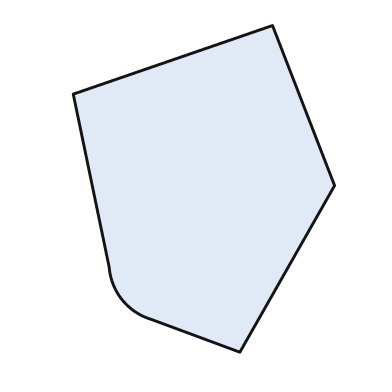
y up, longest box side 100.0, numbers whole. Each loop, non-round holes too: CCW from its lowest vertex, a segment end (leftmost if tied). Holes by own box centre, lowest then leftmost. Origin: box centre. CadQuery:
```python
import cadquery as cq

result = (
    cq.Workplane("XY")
    .moveTo(11.0, -50.0)
    .lineTo(40.0, 1.0)
    .lineTo(21.0, 50.0)
    .lineTo(-40.0, 29.0)
    .lineTo(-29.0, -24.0)
    .threePointArc((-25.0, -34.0), (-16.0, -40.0))
    .close()
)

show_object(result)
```